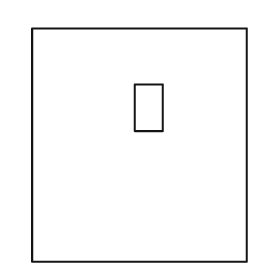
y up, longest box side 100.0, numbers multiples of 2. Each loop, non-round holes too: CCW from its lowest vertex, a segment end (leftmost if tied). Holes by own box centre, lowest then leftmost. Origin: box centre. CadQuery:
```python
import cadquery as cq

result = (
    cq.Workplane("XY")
    .moveTo(-46.0, -50.0)
    .lineTo(46.0, -50.0)
    .lineTo(46.0, 50.0)
    .lineTo(-46.0, 50.0)
    .close()
    .moveTo(-2.0, 6.0)
    .lineTo(10.0, 6.0)
    .lineTo(10.0, 26.0)
    .lineTo(-2.0, 26.0)
    .close()
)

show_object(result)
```